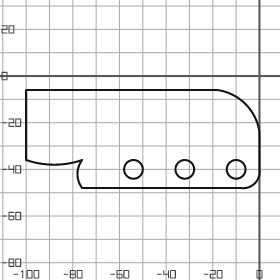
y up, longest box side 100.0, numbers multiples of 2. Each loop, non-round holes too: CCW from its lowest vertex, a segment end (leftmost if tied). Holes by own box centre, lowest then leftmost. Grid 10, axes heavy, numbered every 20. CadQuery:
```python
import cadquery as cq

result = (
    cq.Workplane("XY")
    .moveTo(-76.0, -48.0)
    .lineTo(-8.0, -48.0)
    .threePointArc((-2.0, -46.0), (0.0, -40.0))
    .lineTo(0.0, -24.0)
    .threePointArc((-6.0, -12.0), (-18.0, -6.0))
    .lineTo(-100.0, -6.0)
    .lineTo(-100.0, -36.0)
    .threePointArc((-88.0, -38.0), (-76.0, -36.0))
    .threePointArc((-78.0, -42.0), (-76.0, -48.0))
    .close()
    .moveTo(-54.0, -40.0)
    .circle(4.0)
    .moveTo(-32.0, -40.0)
    .circle(4.0)
    .moveTo(-10.0, -40.0)
    .circle(4.0)
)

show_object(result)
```